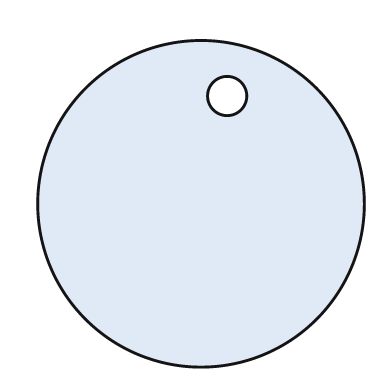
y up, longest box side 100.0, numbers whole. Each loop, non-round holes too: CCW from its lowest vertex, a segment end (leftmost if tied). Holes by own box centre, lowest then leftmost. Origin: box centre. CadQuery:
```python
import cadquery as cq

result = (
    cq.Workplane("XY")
    .moveTo(0.0, 0.0)
    .circle(50.0)
    .moveTo(8.0, 33.0)
    .circle(6.0)
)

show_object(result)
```